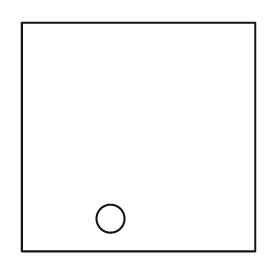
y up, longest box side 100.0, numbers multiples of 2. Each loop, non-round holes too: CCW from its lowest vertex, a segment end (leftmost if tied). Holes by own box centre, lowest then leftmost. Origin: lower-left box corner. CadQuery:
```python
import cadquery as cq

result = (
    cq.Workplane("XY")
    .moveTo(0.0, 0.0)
    .lineTo(100.0, 0.0)
    .lineTo(100.0, 98.0)
    .lineTo(0.0, 98.0)
    .close()
    .moveTo(38.0, 14.0)
    .circle(6.0)
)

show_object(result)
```